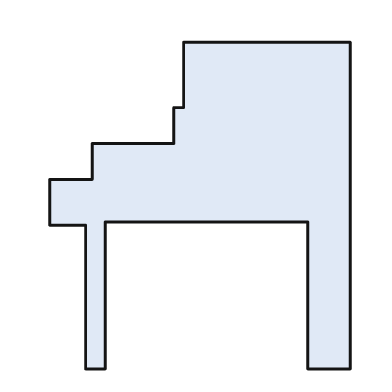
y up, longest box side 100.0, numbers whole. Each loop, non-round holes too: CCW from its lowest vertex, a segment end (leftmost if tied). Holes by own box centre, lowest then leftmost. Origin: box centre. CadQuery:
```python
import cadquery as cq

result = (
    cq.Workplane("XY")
    .moveTo(-35.0, -50.0)
    .lineTo(-29.0, -50.0)
    .lineTo(-29.0, -5.0)
    .lineTo(33.0, -5.0)
    .lineTo(33.0, -50.0)
    .lineTo(46.0, -50.0)
    .lineTo(46.0, 50.0)
    .lineTo(-5.0, 50.0)
    .lineTo(-5.0, 30.0)
    .lineTo(-8.0, 30.0)
    .lineTo(-8.0, 19.0)
    .lineTo(-33.0, 19.0)
    .lineTo(-33.0, 8.0)
    .lineTo(-46.0, 8.0)
    .lineTo(-46.0, -6.0)
    .lineTo(-35.0, -6.0)
    .close()
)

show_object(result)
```